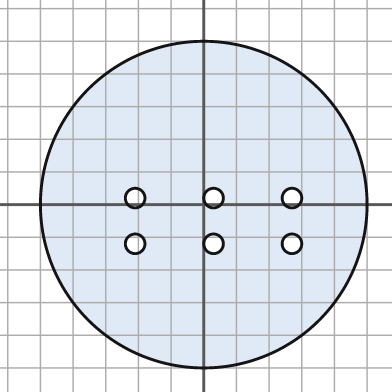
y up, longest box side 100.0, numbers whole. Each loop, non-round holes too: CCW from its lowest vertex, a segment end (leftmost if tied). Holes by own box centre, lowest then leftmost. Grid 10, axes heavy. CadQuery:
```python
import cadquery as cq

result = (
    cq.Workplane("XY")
    .moveTo(0.0, 0.0)
    .circle(50.0)
    .moveTo(-21.0, -12.0)
    .circle(3.0)
    .moveTo(3.0, -12.0)
    .circle(3.0)
    .moveTo(27.0, -12.0)
    .circle(3.0)
    .moveTo(-21.0, 2.0)
    .circle(3.0)
    .moveTo(3.0, 2.0)
    .circle(3.0)
    .moveTo(27.0, 2.0)
    .circle(3.0)
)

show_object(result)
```